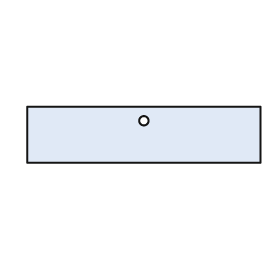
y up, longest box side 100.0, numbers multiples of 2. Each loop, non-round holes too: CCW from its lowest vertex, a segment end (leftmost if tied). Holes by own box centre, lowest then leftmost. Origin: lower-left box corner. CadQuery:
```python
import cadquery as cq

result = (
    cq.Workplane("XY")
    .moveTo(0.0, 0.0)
    .lineTo(100.0, 0.0)
    .lineTo(100.0, 24.0)
    .lineTo(0.0, 24.0)
    .close()
    .moveTo(50.0, 18.0)
    .circle(2.0)
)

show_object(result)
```